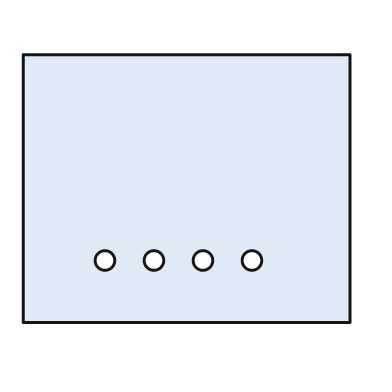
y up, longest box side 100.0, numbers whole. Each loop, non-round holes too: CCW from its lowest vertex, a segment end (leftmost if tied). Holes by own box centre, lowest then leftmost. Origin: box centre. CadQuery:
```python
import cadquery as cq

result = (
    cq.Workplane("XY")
    .moveTo(-50.0, -41.0)
    .lineTo(50.0, -41.0)
    .lineTo(50.0, 41.0)
    .lineTo(-50.0, 41.0)
    .close()
    .moveTo(-25.0, -22.0)
    .circle(3.0)
    .moveTo(-10.0, -22.0)
    .circle(3.0)
    .moveTo(5.0, -22.0)
    .circle(3.0)
    .moveTo(20.0, -22.0)
    .circle(3.0)
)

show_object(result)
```